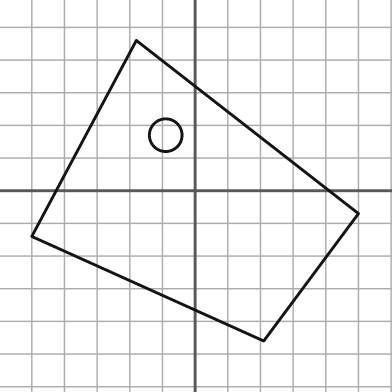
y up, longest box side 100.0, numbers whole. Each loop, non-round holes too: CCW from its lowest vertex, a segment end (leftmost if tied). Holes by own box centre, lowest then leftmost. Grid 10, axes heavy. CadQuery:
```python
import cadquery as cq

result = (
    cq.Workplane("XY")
    .moveTo(21.0, -46.0)
    .lineTo(50.0, -7.0)
    .lineTo(-18.0, 46.0)
    .lineTo(-50.0, -14.0)
    .close()
    .moveTo(-9.0, 17.0)
    .circle(5.0)
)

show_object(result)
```